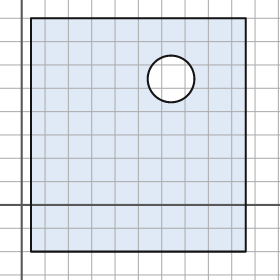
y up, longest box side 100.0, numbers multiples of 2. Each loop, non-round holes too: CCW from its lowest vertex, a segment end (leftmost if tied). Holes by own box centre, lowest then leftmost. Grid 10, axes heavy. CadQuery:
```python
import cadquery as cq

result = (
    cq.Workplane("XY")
    .moveTo(4.0, -20.0)
    .lineTo(96.0, -20.0)
    .lineTo(96.0, 80.0)
    .lineTo(4.0, 80.0)
    .close()
    .moveTo(64.0, 54.0)
    .circle(10.0)
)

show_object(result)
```